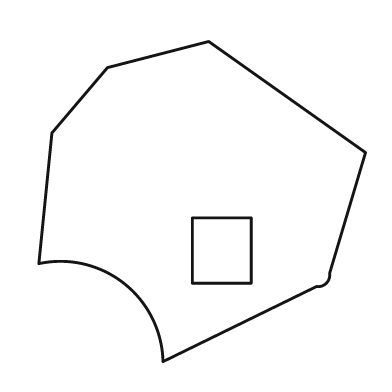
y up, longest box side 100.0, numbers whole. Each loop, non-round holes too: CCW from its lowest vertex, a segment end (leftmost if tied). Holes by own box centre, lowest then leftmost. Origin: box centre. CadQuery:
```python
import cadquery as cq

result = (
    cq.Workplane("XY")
    .moveTo(-12.0, -49.0)
    .lineTo(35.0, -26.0)
    .threePointArc((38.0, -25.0), (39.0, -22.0))
    .lineTo(50.0, 15.0)
    .lineTo(2.0, 49.0)
    .lineTo(-29.0, 41.0)
    .lineTo(-46.0, 21.0)
    .lineTo(-50.0, -19.0)
    .threePointArc((-24.0, -25.0), (-12.0, -49.0))
    .close()
    .moveTo(-3.0, -25.0)
    .lineTo(15.0, -25.0)
    .lineTo(15.0, -5.0)
    .lineTo(-3.0, -5.0)
    .close()
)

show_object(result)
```